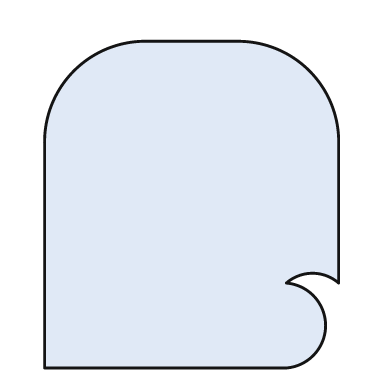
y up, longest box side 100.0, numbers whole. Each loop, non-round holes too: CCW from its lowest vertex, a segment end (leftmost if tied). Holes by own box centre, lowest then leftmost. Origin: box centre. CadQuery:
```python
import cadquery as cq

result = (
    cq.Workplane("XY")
    .moveTo(-45.0, -50.0)
    .lineTo(29.0, -50.0)
    .threePointArc((41.0, -37.0), (29.0, -24.0))
    .threePointArc((37.0, -21.0), (45.0, -24.0))
    .lineTo(45.0, 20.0)
    .threePointArc((36.0, 41.0), (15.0, 50.0))
    .lineTo(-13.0, 50.0)
    .threePointArc((-36.0, 41.0), (-45.0, 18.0))
    .close()
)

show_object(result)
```